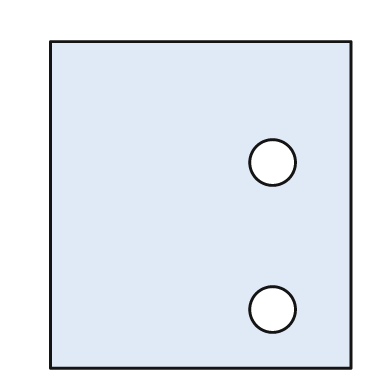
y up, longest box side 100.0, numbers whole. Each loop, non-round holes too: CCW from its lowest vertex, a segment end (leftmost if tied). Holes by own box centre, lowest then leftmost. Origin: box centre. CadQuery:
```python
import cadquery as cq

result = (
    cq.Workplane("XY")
    .moveTo(-46.0, -50.0)
    .lineTo(46.0, -50.0)
    .lineTo(46.0, 50.0)
    .lineTo(-46.0, 50.0)
    .close()
    .moveTo(22.0, -32.0)
    .circle(7.0)
    .moveTo(22.0, 13.0)
    .circle(7.0)
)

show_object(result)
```